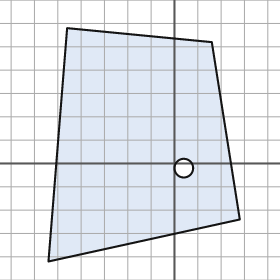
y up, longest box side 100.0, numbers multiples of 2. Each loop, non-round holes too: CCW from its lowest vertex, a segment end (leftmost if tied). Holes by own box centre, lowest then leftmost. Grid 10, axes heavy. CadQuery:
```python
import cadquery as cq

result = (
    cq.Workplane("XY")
    .moveTo(-54.0, -42.0)
    .lineTo(28.0, -24.0)
    .lineTo(16.0, 52.0)
    .lineTo(-46.0, 58.0)
    .close()
    .moveTo(4.0, -2.0)
    .circle(4.0)
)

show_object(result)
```